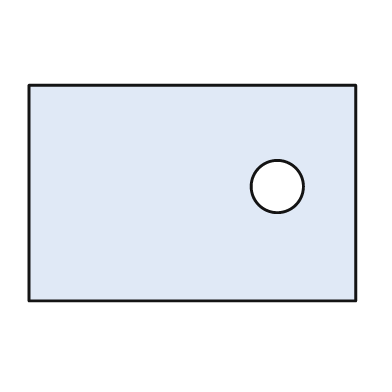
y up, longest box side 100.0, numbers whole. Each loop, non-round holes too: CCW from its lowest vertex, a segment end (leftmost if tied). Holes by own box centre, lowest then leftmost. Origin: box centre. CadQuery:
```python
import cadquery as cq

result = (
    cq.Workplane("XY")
    .moveTo(-50.0, -33.0)
    .lineTo(50.0, -33.0)
    .lineTo(50.0, 33.0)
    .lineTo(-50.0, 33.0)
    .close()
    .moveTo(26.0, 2.0)
    .circle(8.0)
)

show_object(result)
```